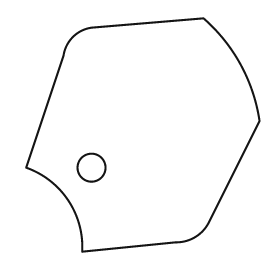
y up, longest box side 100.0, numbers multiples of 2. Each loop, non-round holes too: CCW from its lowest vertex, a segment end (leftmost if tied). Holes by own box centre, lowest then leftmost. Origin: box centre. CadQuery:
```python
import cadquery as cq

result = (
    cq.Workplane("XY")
    .moveTo(-26.0, -50.0)
    .lineTo(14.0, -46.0)
    .threePointArc((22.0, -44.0), (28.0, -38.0))
    .lineTo(50.0, 6.0)
    .threePointArc((42.0, 30.0), (26.0, 50.0))
    .lineTo(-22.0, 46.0)
    .threePointArc((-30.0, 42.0), (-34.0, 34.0))
    .lineTo(-50.0, -14.0)
    .threePointArc((-32.0, -28.0), (-26.0, -50.0))
    .close()
    .moveTo(-22.0, -14.0)
    .circle(6.0)
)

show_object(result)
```